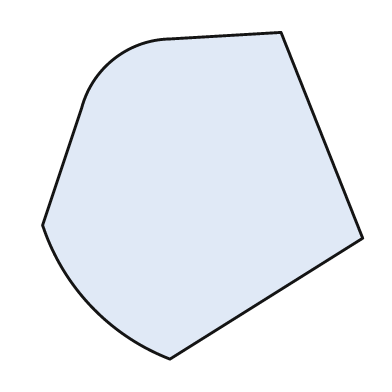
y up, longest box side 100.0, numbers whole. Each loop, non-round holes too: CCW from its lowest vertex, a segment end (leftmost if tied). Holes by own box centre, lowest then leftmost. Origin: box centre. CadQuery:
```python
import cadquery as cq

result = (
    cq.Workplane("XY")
    .moveTo(-10.0, -50.0)
    .lineTo(49.0, -13.0)
    .lineTo(24.0, 50.0)
    .lineTo(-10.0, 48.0)
    .threePointArc((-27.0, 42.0), (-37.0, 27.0))
    .lineTo(-49.0, -9.0)
    .threePointArc((-34.0, -34.0), (-10.0, -50.0))
    .close()
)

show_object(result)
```